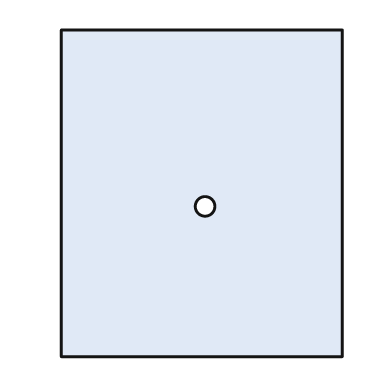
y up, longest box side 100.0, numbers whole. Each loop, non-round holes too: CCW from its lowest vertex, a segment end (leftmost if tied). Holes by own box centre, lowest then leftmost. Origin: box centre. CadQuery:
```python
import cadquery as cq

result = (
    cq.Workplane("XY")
    .moveTo(-43.0, -50.0)
    .lineTo(43.0, -50.0)
    .lineTo(43.0, 50.0)
    .lineTo(-43.0, 50.0)
    .close()
    .moveTo(1.0, -4.0)
    .circle(3.0)
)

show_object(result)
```